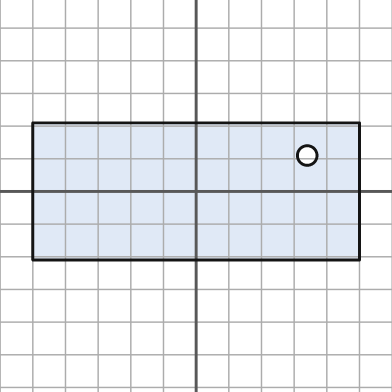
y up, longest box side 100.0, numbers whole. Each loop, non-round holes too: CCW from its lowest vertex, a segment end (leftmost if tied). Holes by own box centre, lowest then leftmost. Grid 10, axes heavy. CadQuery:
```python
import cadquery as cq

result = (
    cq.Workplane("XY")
    .moveTo(-50.0, -21.0)
    .lineTo(50.0, -21.0)
    .lineTo(50.0, 21.0)
    .lineTo(-50.0, 21.0)
    .close()
    .moveTo(34.0, 11.0)
    .circle(3.0)
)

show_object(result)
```